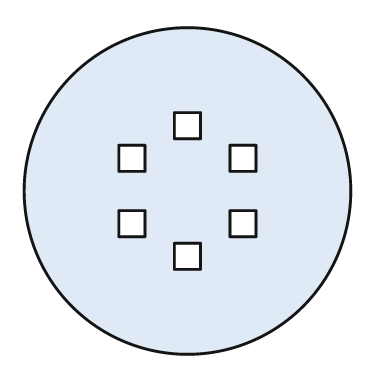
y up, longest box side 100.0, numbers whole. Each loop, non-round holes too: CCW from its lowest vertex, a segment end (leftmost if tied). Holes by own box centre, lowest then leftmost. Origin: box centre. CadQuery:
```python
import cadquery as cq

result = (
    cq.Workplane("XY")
    .moveTo(0.0, 0.0)
    .circle(50.0)
    .moveTo(-4.0, -24.0)
    .lineTo(4.0, -24.0)
    .lineTo(4.0, -16.0)
    .lineTo(-4.0, -16.0)
    .close()
    .moveTo(-21.0, -14.0)
    .lineTo(-13.0, -14.0)
    .lineTo(-13.0, -6.0)
    .lineTo(-21.0, -6.0)
    .close()
    .moveTo(13.0, -14.0)
    .lineTo(21.0, -14.0)
    .lineTo(21.0, -6.0)
    .lineTo(13.0, -6.0)
    .close()
    .moveTo(-21.0, 6.0)
    .lineTo(-13.0, 6.0)
    .lineTo(-13.0, 14.0)
    .lineTo(-21.0, 14.0)
    .close()
    .moveTo(13.0, 6.0)
    .lineTo(21.0, 6.0)
    .lineTo(21.0, 14.0)
    .lineTo(13.0, 14.0)
    .close()
    .moveTo(-4.0, 16.0)
    .lineTo(4.0, 16.0)
    .lineTo(4.0, 24.0)
    .lineTo(-4.0, 24.0)
    .close()
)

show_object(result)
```